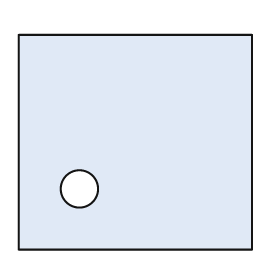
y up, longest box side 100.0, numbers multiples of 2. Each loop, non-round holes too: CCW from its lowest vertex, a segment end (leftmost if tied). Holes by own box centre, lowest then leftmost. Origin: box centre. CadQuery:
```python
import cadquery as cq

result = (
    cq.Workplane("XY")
    .moveTo(-50.0, -46.0)
    .lineTo(50.0, -46.0)
    .lineTo(50.0, 46.0)
    .lineTo(-50.0, 46.0)
    .close()
    .moveTo(-24.0, -20.0)
    .circle(8.0)
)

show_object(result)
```